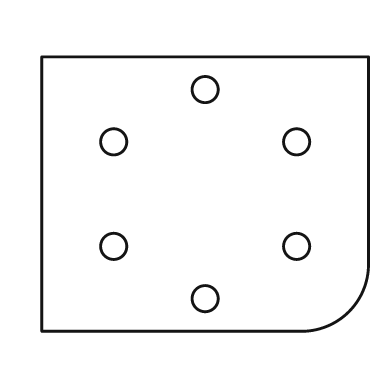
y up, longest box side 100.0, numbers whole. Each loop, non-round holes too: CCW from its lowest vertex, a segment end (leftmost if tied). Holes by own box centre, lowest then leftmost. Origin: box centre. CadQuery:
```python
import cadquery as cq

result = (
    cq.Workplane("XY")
    .moveTo(-50.0, -42.0)
    .lineTo(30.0, -42.0)
    .threePointArc((44.0, -36.0), (50.0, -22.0))
    .lineTo(50.0, 42.0)
    .lineTo(-50.0, 42.0)
    .close()
    .moveTo(0.0, -32.0)
    .circle(4.0)
    .moveTo(-28.0, -16.0)
    .circle(4.0)
    .moveTo(28.0, -16.0)
    .circle(4.0)
    .moveTo(-28.0, 16.0)
    .circle(4.0)
    .moveTo(28.0, 16.0)
    .circle(4.0)
    .moveTo(0.0, 32.0)
    .circle(4.0)
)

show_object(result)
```